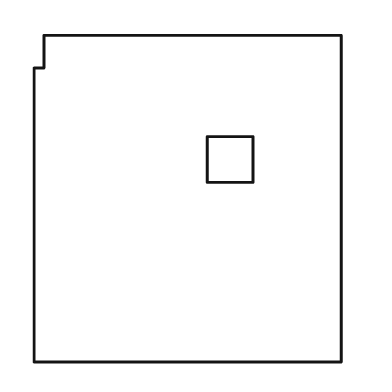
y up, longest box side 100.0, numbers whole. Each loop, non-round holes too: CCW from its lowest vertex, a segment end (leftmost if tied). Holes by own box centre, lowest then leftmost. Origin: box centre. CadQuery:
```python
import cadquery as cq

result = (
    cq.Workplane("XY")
    .moveTo(-47.0, -50.0)
    .lineTo(47.0, -50.0)
    .lineTo(47.0, 50.0)
    .lineTo(-44.0, 50.0)
    .lineTo(-44.0, 40.0)
    .lineTo(-47.0, 40.0)
    .close()
    .moveTo(6.0, 5.0)
    .lineTo(20.0, 5.0)
    .lineTo(20.0, 19.0)
    .lineTo(6.0, 19.0)
    .close()
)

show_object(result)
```